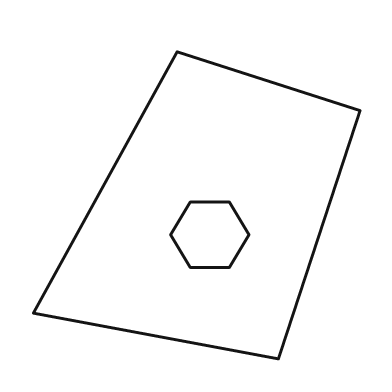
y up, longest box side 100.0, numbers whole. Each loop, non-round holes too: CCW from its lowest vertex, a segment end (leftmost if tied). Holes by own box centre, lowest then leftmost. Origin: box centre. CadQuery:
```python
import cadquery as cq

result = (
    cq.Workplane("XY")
    .moveTo(25.0, -47.0)
    .lineTo(50.0, 29.0)
    .lineTo(-6.0, 47.0)
    .lineTo(-50.0, -33.0)
    .close()
    .moveTo(-2.0, -19.0)
    .lineTo(10.0, -19.0)
    .lineTo(16.0, -9.0)
    .lineTo(10.0, 1.0)
    .lineTo(-2.0, 1.0)
    .lineTo(-8.0, -9.0)
    .close()
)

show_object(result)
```